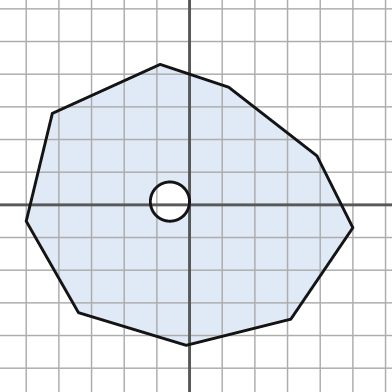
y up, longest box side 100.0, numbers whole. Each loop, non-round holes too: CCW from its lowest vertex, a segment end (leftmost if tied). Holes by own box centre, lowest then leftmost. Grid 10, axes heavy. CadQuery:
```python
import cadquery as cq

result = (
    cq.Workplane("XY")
    .moveTo(-1.0, -43.0)
    .lineTo(31.0, -35.0)
    .lineTo(50.0, -7.0)
    .lineTo(39.0, 15.0)
    .lineTo(12.0, 36.0)
    .lineTo(-9.0, 43.0)
    .lineTo(-42.0, 28.0)
    .lineTo(-50.0, -5.0)
    .lineTo(-34.0, -33.0)
    .close()
    .moveTo(-6.0, 1.0)
    .circle(6.0)
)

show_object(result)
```